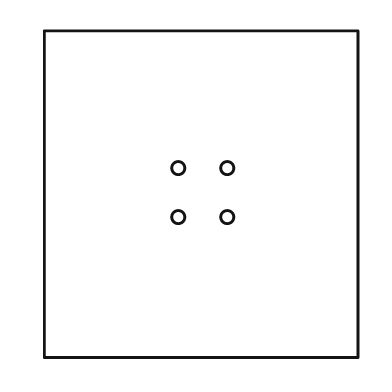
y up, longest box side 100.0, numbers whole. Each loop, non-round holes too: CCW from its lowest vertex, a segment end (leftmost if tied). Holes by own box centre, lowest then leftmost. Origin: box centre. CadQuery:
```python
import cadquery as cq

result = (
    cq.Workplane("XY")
    .moveTo(-48.0, -50.0)
    .lineTo(48.0, -50.0)
    .lineTo(48.0, 50.0)
    .lineTo(-48.0, 50.0)
    .close()
    .moveTo(-7.0, -7.0)
    .circle(2.0)
    .moveTo(8.0, -7.0)
    .circle(2.0)
    .moveTo(-7.0, 8.0)
    .circle(2.0)
    .moveTo(8.0, 8.0)
    .circle(2.0)
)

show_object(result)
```